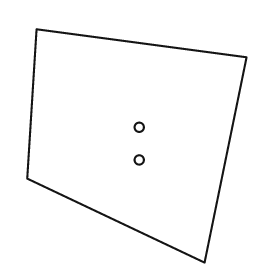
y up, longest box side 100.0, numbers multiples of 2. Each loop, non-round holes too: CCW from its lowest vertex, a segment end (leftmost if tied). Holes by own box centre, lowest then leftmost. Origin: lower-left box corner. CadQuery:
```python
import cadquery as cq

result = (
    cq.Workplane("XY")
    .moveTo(76.0, 0.0)
    .lineTo(94.0, 88.0)
    .lineTo(4.0, 100.0)
    .lineTo(0.0, 36.0)
    .close()
    .moveTo(48.0, 44.0)
    .circle(2.0)
    .moveTo(48.0, 58.0)
    .circle(2.0)
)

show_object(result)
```